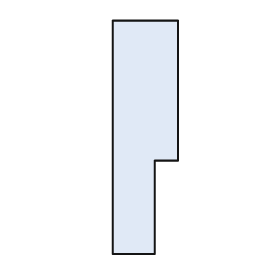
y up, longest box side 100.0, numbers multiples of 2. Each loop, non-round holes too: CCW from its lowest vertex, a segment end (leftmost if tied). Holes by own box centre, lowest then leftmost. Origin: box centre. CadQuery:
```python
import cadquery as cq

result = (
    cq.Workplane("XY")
    .moveTo(-14.0, -50.0)
    .lineTo(4.0, -50.0)
    .lineTo(4.0, -10.0)
    .lineTo(14.0, -10.0)
    .lineTo(14.0, 50.0)
    .lineTo(-14.0, 50.0)
    .close()
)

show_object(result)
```